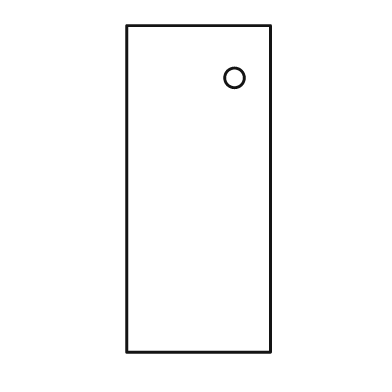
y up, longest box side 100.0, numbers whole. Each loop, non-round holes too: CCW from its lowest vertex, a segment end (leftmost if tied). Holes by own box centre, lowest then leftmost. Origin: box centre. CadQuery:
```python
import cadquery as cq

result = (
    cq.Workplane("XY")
    .moveTo(-22.0, -50.0)
    .lineTo(22.0, -50.0)
    .lineTo(22.0, 50.0)
    .lineTo(-22.0, 50.0)
    .close()
    .moveTo(11.0, 34.0)
    .circle(3.0)
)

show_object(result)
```